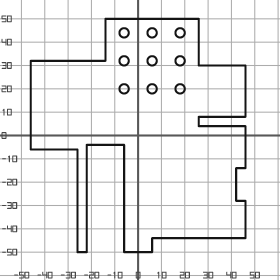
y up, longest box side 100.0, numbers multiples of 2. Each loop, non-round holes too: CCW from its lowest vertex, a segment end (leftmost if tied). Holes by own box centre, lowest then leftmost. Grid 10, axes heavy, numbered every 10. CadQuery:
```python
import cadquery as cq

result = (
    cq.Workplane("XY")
    .moveTo(-26.0, -50.0)
    .lineTo(-22.0, -50.0)
    .lineTo(-22.0, -4.0)
    .lineTo(-6.0, -4.0)
    .lineTo(-6.0, -50.0)
    .lineTo(6.0, -50.0)
    .lineTo(6.0, -44.0)
    .lineTo(46.0, -44.0)
    .lineTo(46.0, -28.0)
    .lineTo(42.0, -28.0)
    .lineTo(42.0, -14.0)
    .lineTo(46.0, -14.0)
    .lineTo(46.0, 4.0)
    .lineTo(26.0, 4.0)
    .lineTo(26.0, 8.0)
    .lineTo(46.0, 8.0)
    .lineTo(46.0, 30.0)
    .lineTo(26.0, 30.0)
    .lineTo(26.0, 50.0)
    .lineTo(-14.0, 50.0)
    .lineTo(-14.0, 32.0)
    .lineTo(-46.0, 32.0)
    .lineTo(-46.0, -6.0)
    .lineTo(-26.0, -6.0)
    .close()
    .moveTo(-6.0, 20.0)
    .circle(2.0)
    .moveTo(6.0, 20.0)
    .circle(2.0)
    .moveTo(18.0, 20.0)
    .circle(2.0)
    .moveTo(-6.0, 32.0)
    .circle(2.0)
    .moveTo(6.0, 32.0)
    .circle(2.0)
    .moveTo(18.0, 32.0)
    .circle(2.0)
    .moveTo(-6.0, 44.0)
    .circle(2.0)
    .moveTo(6.0, 44.0)
    .circle(2.0)
    .moveTo(18.0, 44.0)
    .circle(2.0)
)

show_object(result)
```